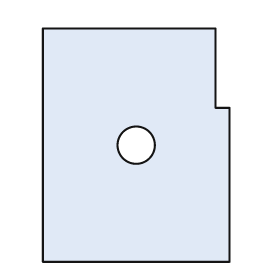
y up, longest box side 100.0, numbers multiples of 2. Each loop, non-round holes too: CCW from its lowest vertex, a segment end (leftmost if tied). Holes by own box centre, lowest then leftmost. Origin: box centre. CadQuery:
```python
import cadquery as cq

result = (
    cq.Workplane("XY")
    .moveTo(-40.0, -50.0)
    .lineTo(40.0, -50.0)
    .lineTo(40.0, 16.0)
    .lineTo(34.0, 16.0)
    .lineTo(34.0, 50.0)
    .lineTo(-40.0, 50.0)
    .close()
    .moveTo(0.0, 0.0)
    .circle(8.0)
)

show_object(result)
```